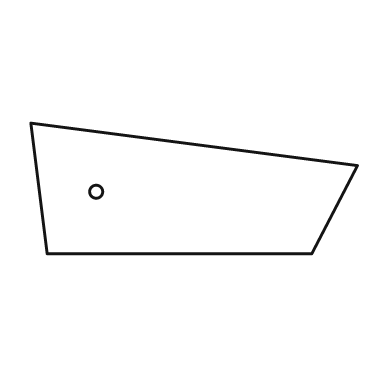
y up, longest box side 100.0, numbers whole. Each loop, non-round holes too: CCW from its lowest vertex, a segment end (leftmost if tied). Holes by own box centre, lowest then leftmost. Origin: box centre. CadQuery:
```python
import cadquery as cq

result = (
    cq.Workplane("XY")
    .moveTo(-45.0, -20.0)
    .lineTo(36.0, -20.0)
    .lineTo(50.0, 7.0)
    .lineTo(-50.0, 20.0)
    .close()
    .moveTo(-30.0, -1.0)
    .circle(2.0)
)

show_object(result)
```